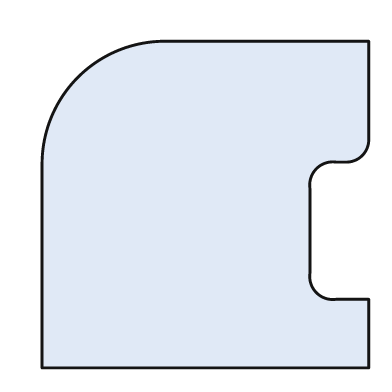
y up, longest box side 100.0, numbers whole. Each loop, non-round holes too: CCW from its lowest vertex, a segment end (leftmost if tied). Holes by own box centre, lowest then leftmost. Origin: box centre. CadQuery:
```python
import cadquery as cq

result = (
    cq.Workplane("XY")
    .moveTo(-50.0, -50.0)
    .lineTo(50.0, -50.0)
    .lineTo(50.0, -29.0)
    .lineTo(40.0, -29.0)
    .threePointArc((34.0, -27.0), (32.0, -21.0))
    .lineTo(32.0, 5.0)
    .threePointArc((34.0, 11.0), (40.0, 13.0))
    .lineTo(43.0, 13.0)
    .threePointArc((48.0, 15.0), (50.0, 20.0))
    .lineTo(50.0, 50.0)
    .lineTo(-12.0, 50.0)
    .threePointArc((-39.0, 39.0), (-50.0, 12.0))
    .close()
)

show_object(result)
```